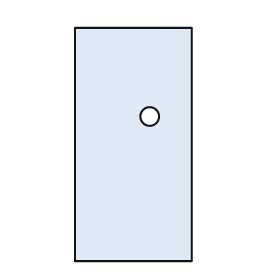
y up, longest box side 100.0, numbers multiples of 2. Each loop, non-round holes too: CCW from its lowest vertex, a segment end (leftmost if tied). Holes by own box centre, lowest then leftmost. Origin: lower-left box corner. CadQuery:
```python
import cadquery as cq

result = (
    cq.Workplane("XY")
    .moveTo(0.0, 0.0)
    .lineTo(50.0, 0.0)
    .lineTo(50.0, 100.0)
    .lineTo(0.0, 100.0)
    .close()
    .moveTo(32.0, 62.0)
    .circle(4.0)
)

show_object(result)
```